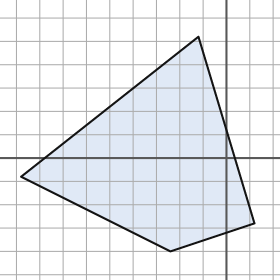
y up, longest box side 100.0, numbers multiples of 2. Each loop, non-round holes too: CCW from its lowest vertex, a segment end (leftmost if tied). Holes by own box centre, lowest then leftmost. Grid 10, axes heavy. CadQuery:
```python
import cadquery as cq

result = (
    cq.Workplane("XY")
    .moveTo(-24.0, -40.0)
    .lineTo(12.0, -28.0)
    .lineTo(-12.0, 52.0)
    .lineTo(-88.0, -8.0)
    .close()
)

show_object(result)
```